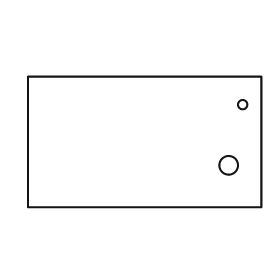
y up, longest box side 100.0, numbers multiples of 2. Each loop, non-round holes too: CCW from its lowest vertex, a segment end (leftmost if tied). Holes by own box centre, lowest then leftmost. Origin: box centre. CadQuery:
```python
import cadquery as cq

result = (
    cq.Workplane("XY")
    .moveTo(-50.0, -28.0)
    .lineTo(50.0, -28.0)
    .lineTo(50.0, 28.0)
    .lineTo(-50.0, 28.0)
    .close()
    .moveTo(36.0, -10.0)
    .circle(4.0)
    .moveTo(42.0, 16.0)
    .circle(2.0)
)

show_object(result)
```